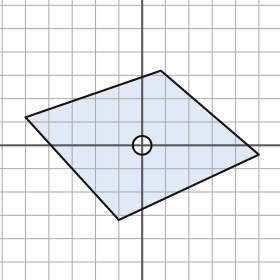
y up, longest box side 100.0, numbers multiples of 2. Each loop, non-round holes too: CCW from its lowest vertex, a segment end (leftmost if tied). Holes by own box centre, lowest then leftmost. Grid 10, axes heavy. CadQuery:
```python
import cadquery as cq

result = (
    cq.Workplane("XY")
    .moveTo(-10.0, -32.0)
    .lineTo(50.0, -4.0)
    .lineTo(8.0, 32.0)
    .lineTo(-50.0, 12.0)
    .close()
    .moveTo(0.0, 0.0)
    .circle(4.0)
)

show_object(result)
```